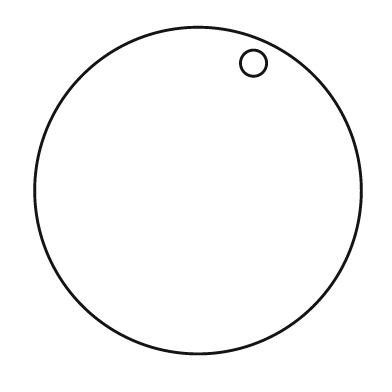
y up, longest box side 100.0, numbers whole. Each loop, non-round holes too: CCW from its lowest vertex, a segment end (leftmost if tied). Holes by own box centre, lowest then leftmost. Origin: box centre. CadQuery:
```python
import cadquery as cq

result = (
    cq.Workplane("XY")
    .moveTo(0.0, 0.0)
    .circle(50.0)
    .moveTo(17.0, 39.0)
    .circle(4.0)
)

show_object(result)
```